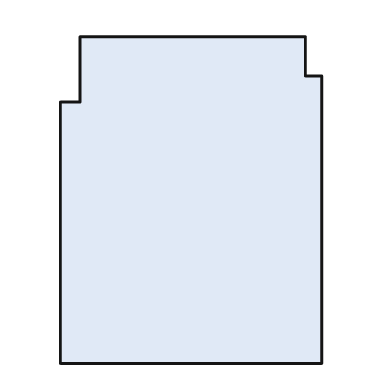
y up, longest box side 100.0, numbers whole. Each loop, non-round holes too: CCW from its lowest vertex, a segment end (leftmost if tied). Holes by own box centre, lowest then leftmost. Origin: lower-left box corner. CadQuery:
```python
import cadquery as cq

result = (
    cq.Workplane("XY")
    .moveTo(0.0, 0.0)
    .lineTo(80.0, 0.0)
    .lineTo(80.0, 88.0)
    .lineTo(75.0, 88.0)
    .lineTo(75.0, 100.0)
    .lineTo(6.0, 100.0)
    .lineTo(6.0, 80.0)
    .lineTo(0.0, 80.0)
    .close()
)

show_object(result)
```